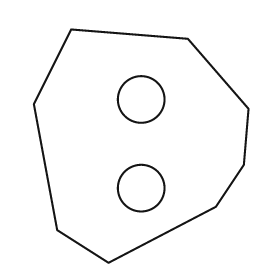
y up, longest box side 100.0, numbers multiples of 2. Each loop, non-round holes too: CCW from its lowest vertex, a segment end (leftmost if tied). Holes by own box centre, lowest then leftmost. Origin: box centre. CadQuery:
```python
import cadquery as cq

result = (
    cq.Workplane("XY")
    .moveTo(-14.0, -50.0)
    .lineTo(32.0, -26.0)
    .lineTo(44.0, -8.0)
    .lineTo(46.0, 16.0)
    .lineTo(20.0, 46.0)
    .lineTo(-30.0, 50.0)
    .lineTo(-46.0, 18.0)
    .lineTo(-36.0, -36.0)
    .close()
    .moveTo(0.0, -18.0)
    .circle(10.0)
    .moveTo(0.0, 20.0)
    .circle(10.0)
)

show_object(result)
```